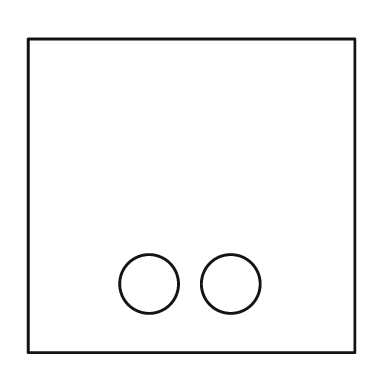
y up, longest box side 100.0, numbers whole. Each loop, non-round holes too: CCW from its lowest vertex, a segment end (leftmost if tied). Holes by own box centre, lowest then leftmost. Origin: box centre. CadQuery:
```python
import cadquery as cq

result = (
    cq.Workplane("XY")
    .moveTo(-50.0, -48.0)
    .lineTo(50.0, -48.0)
    .lineTo(50.0, 48.0)
    .lineTo(-50.0, 48.0)
    .close()
    .moveTo(-13.0, -27.0)
    .circle(9.0)
    .moveTo(12.0, -27.0)
    .circle(9.0)
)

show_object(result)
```